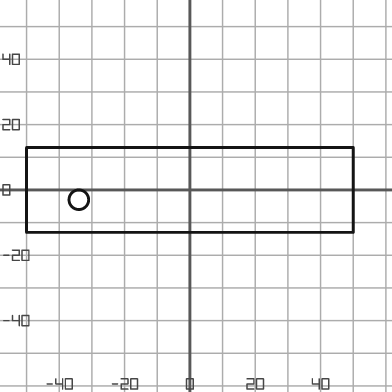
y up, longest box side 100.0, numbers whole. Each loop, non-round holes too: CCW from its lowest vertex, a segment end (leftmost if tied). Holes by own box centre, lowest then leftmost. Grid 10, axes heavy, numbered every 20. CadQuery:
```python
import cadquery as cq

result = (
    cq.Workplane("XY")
    .moveTo(-50.0, -13.0)
    .lineTo(50.0, -13.0)
    .lineTo(50.0, 13.0)
    .lineTo(-50.0, 13.0)
    .close()
    .moveTo(-34.0, -3.0)
    .circle(3.0)
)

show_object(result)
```